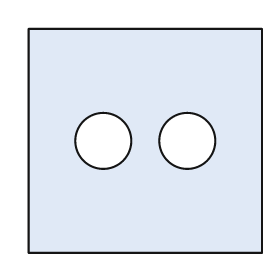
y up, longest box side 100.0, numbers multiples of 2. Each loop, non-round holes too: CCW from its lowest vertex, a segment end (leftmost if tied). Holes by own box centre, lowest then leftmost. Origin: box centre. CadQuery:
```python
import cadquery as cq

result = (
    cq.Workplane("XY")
    .moveTo(-50.0, -48.0)
    .lineTo(50.0, -48.0)
    .lineTo(50.0, 48.0)
    .lineTo(-50.0, 48.0)
    .close()
    .moveTo(-18.0, 0.0)
    .circle(12.0)
    .moveTo(18.0, 0.0)
    .circle(12.0)
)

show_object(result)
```